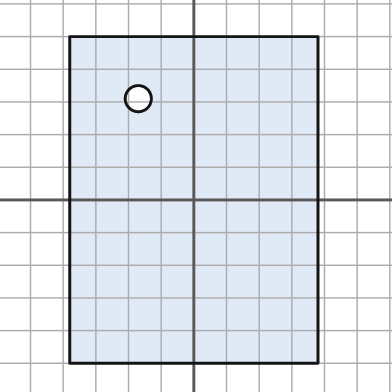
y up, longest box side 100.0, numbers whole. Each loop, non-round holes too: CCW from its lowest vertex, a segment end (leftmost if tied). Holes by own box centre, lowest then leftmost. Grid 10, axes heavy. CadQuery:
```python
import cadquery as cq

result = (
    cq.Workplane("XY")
    .moveTo(-38.0, -50.0)
    .lineTo(38.0, -50.0)
    .lineTo(38.0, 50.0)
    .lineTo(-38.0, 50.0)
    .close()
    .moveTo(-17.0, 31.0)
    .circle(4.0)
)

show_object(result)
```